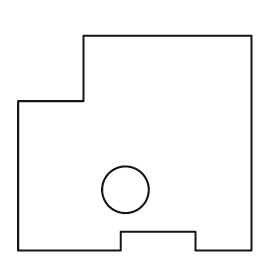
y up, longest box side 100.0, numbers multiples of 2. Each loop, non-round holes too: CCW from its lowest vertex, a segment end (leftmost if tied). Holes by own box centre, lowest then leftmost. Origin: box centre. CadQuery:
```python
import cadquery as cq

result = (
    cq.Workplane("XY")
    .moveTo(-50.0, -46.0)
    .lineTo(-6.0, -46.0)
    .lineTo(-6.0, -38.0)
    .lineTo(26.0, -38.0)
    .lineTo(26.0, -46.0)
    .lineTo(50.0, -46.0)
    .lineTo(50.0, 46.0)
    .lineTo(-22.0, 46.0)
    .lineTo(-22.0, 18.0)
    .lineTo(-50.0, 18.0)
    .close()
    .moveTo(-4.0, -20.0)
    .circle(10.0)
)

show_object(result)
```